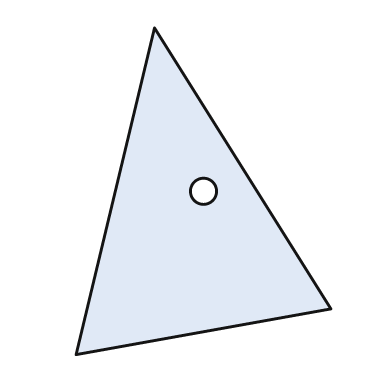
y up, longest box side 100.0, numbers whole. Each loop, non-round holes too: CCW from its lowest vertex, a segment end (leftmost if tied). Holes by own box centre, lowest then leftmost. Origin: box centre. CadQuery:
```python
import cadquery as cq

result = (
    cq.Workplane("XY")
    .moveTo(-39.0, -50.0)
    .lineTo(39.0, -36.0)
    .lineTo(-15.0, 50.0)
    .close()
    .moveTo(0.0, 0.0)
    .circle(4.0)
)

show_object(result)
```